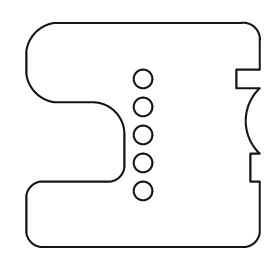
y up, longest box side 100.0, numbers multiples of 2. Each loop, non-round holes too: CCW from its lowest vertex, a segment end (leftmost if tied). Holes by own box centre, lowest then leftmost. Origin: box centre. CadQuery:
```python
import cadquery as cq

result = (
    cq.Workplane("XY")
    .moveTo(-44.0, -48.0)
    .lineTo(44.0, -48.0)
    .threePointArc((48.0, -46.0), (50.0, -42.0))
    .lineTo(50.0, -20.0)
    .lineTo(46.0, -20.0)
    .lineTo(46.0, -8.0)
    .lineTo(50.0, -8.0)
    .threePointArc((44.0, 6.0), (50.0, 20.0))
    .lineTo(40.0, 20.0)
    .lineTo(40.0, 28.0)
    .lineTo(50.0, 28.0)
    .lineTo(50.0, 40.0)
    .threePointArc((48.0, 46.0), (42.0, 48.0))
    .lineTo(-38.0, 48.0)
    .threePointArc((-46.0, 44.0), (-50.0, 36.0))
    .lineTo(-50.0, 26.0)
    .threePointArc((-46.0, 18.0), (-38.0, 14.0))
    .lineTo(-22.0, 14.0)
    .threePointArc((-12.0, 10.0), (-8.0, 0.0))
    .lineTo(-8.0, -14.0)
    .threePointArc((-10.0, -18.0), (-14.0, -20.0))
    .lineTo(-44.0, -20.0)
    .threePointArc((-48.0, -22.0), (-50.0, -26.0))
    .lineTo(-50.0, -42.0)
    .threePointArc((-48.0, -46.0), (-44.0, -48.0))
    .close()
    .moveTo(0.0, -24.0)
    .circle(4.0)
    .moveTo(0.0, -12.0)
    .circle(4.0)
    .moveTo(0.0, 0.0)
    .circle(4.0)
    .moveTo(0.0, 12.0)
    .circle(4.0)
    .moveTo(0.0, 24.0)
    .circle(4.0)
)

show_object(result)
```